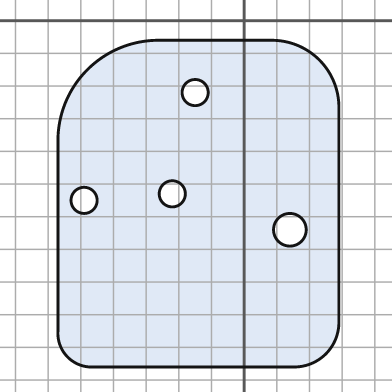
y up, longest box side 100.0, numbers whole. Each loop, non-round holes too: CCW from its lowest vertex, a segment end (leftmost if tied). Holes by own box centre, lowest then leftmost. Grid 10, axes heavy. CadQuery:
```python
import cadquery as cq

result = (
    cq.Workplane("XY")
    .moveTo(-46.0, -106.0)
    .lineTo(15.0, -106.0)
    .threePointArc((25.0, -102.0), (29.0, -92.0))
    .lineTo(29.0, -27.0)
    .threePointArc((23.0, -12.0), (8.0, -6.0))
    .lineTo(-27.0, -6.0)
    .threePointArc((-48.0, -15.0), (-57.0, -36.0))
    .lineTo(-57.0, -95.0)
    .threePointArc((-54.0, -103.0), (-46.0, -106.0))
    .close()
    .moveTo(14.0, -64.0)
    .circle(5.0)
    .moveTo(-49.0, -55.0)
    .circle(4.0)
    .moveTo(-22.0, -53.0)
    .circle(4.0)
    .moveTo(-15.0, -22.0)
    .circle(4.0)
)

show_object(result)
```